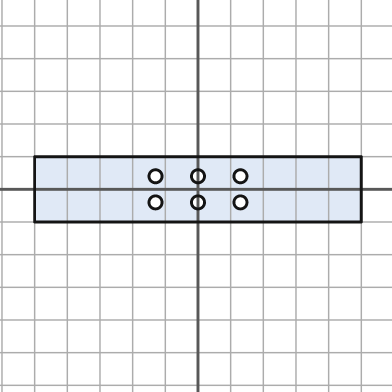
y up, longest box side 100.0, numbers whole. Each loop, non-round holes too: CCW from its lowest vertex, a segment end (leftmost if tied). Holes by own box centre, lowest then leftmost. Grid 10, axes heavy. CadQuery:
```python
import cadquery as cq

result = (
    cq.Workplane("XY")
    .moveTo(-50.0, -10.0)
    .lineTo(50.0, -10.0)
    .lineTo(50.0, 10.0)
    .lineTo(-50.0, 10.0)
    .close()
    .moveTo(-13.0, -4.0)
    .circle(2.0)
    .moveTo(0.0, -4.0)
    .circle(2.0)
    .moveTo(13.0, -4.0)
    .circle(2.0)
    .moveTo(-13.0, 4.0)
    .circle(2.0)
    .moveTo(0.0, 4.0)
    .circle(2.0)
    .moveTo(13.0, 4.0)
    .circle(2.0)
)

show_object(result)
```